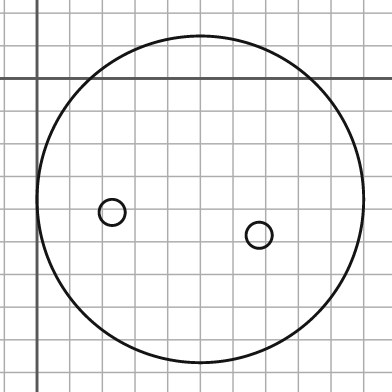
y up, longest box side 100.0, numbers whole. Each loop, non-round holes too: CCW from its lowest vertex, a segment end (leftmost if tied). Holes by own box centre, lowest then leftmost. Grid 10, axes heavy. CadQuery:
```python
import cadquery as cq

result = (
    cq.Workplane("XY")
    .moveTo(50.0, -37.0)
    .circle(50.0)
    .moveTo(68.0, -48.0)
    .circle(4.0)
    .moveTo(23.0, -41.0)
    .circle(4.0)
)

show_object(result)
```